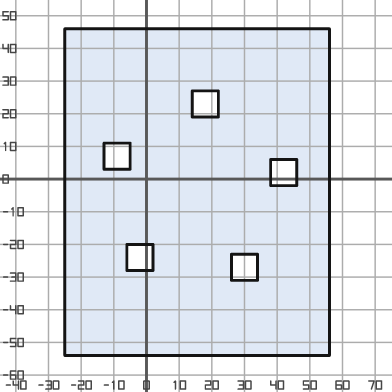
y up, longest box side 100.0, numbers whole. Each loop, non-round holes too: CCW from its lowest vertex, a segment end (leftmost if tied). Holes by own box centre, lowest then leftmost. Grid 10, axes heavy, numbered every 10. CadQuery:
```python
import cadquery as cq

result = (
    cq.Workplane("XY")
    .moveTo(-25.0, -54.0)
    .lineTo(56.0, -54.0)
    .lineTo(56.0, 46.0)
    .lineTo(-25.0, 46.0)
    .close()
    .moveTo(26.0, -31.0)
    .lineTo(34.0, -31.0)
    .lineTo(34.0, -23.0)
    .lineTo(26.0, -23.0)
    .close()
    .moveTo(-6.0, -28.0)
    .lineTo(2.0, -28.0)
    .lineTo(2.0, -20.0)
    .lineTo(-6.0, -20.0)
    .close()
    .moveTo(38.0, -2.0)
    .lineTo(46.0, -2.0)
    .lineTo(46.0, 6.0)
    .lineTo(38.0, 6.0)
    .close()
    .moveTo(-13.0, 3.0)
    .lineTo(-5.0, 3.0)
    .lineTo(-5.0, 11.0)
    .lineTo(-13.0, 11.0)
    .close()
    .moveTo(14.0, 19.0)
    .lineTo(22.0, 19.0)
    .lineTo(22.0, 27.0)
    .lineTo(14.0, 27.0)
    .close()
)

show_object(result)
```